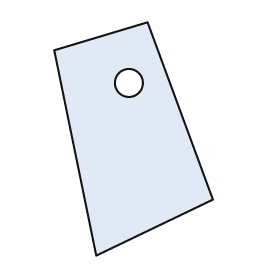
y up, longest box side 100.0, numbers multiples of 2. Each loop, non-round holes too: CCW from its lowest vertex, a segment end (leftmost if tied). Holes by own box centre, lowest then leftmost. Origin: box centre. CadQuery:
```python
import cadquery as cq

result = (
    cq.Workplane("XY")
    .moveTo(-16.0, -50.0)
    .lineTo(34.0, -26.0)
    .lineTo(6.0, 50.0)
    .lineTo(-34.0, 38.0)
    .close()
    .moveTo(-2.0, 24.0)
    .circle(6.0)
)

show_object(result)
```